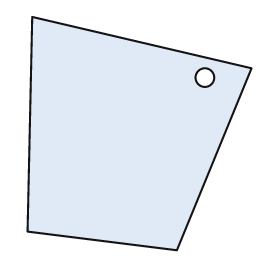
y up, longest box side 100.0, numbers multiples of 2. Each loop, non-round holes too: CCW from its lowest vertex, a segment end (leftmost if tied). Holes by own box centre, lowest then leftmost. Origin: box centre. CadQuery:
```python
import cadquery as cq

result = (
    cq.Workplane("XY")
    .moveTo(16.0, -50.0)
    .lineTo(48.0, 28.0)
    .lineTo(-46.0, 50.0)
    .lineTo(-48.0, -42.0)
    .close()
    .moveTo(28.0, 24.0)
    .circle(4.0)
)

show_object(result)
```